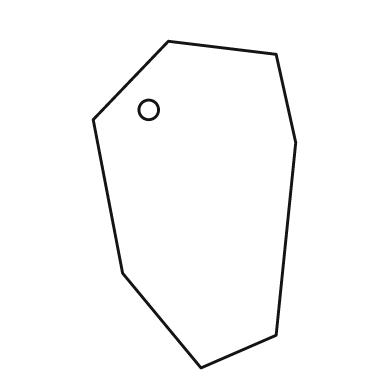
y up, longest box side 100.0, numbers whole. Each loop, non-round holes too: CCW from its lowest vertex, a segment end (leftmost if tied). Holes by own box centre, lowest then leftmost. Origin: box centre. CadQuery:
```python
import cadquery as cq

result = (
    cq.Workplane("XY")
    .moveTo(2.0, -50.0)
    .lineTo(25.0, -40.0)
    .lineTo(31.0, 19.0)
    .lineTo(25.0, 46.0)
    .lineTo(-8.0, 50.0)
    .lineTo(-31.0, 26.0)
    .lineTo(-22.0, -21.0)
    .close()
    .moveTo(-14.0, 29.0)
    .circle(3.0)
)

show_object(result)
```